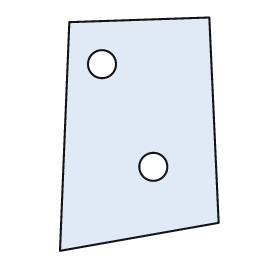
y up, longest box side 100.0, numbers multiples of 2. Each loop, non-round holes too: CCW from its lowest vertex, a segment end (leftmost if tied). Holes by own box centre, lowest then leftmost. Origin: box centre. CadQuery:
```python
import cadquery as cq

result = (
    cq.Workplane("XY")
    .moveTo(-34.0, -50.0)
    .lineTo(34.0, -38.0)
    .lineTo(30.0, 50.0)
    .lineTo(-30.0, 48.0)
    .close()
    .moveTo(6.0, -14.0)
    .circle(6.0)
    .moveTo(-16.0, 30.0)
    .circle(6.0)
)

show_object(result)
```